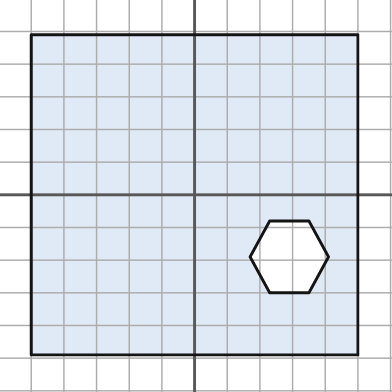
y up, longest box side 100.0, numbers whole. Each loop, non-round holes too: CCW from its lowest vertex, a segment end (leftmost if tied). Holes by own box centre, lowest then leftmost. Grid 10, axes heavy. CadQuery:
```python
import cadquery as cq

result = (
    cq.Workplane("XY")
    .moveTo(-50.0, -49.0)
    .lineTo(50.0, -49.0)
    .lineTo(50.0, 49.0)
    .lineTo(-50.0, 49.0)
    .close()
    .moveTo(23.0, -30.0)
    .lineTo(35.0, -30.0)
    .lineTo(41.0, -19.0)
    .lineTo(35.0, -8.0)
    .lineTo(23.0, -8.0)
    .lineTo(17.0, -19.0)
    .close()
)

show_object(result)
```